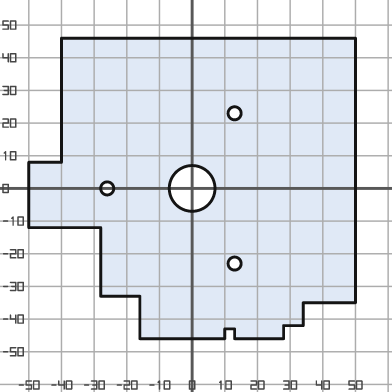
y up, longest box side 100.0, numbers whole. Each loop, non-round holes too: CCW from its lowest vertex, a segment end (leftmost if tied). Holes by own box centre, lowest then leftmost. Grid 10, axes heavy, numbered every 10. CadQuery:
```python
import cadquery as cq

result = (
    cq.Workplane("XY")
    .moveTo(-16.0, -46.0)
    .lineTo(10.0, -46.0)
    .lineTo(10.0, -43.0)
    .lineTo(13.0, -43.0)
    .lineTo(13.0, -46.0)
    .lineTo(28.0, -46.0)
    .lineTo(28.0, -42.0)
    .lineTo(34.0, -42.0)
    .lineTo(34.0, -35.0)
    .lineTo(50.0, -35.0)
    .lineTo(50.0, 46.0)
    .lineTo(-40.0, 46.0)
    .lineTo(-40.0, 8.0)
    .lineTo(-50.0, 8.0)
    .lineTo(-50.0, -12.0)
    .lineTo(-28.0, -12.0)
    .lineTo(-28.0, -33.0)
    .lineTo(-16.0, -33.0)
    .close()
    .moveTo(13.0, -23.0)
    .circle(2.0)
    .moveTo(-26.0, 0.0)
    .circle(2.0)
    .moveTo(0.0, 0.0)
    .circle(7.0)
    .moveTo(13.0, 23.0)
    .circle(2.0)
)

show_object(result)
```